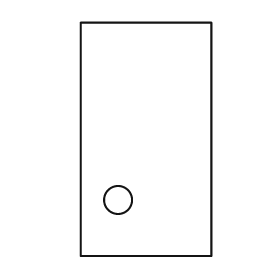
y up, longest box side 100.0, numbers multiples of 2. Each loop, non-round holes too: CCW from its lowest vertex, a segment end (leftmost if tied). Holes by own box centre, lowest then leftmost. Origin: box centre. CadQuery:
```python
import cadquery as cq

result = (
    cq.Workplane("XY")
    .moveTo(-28.0, -50.0)
    .lineTo(28.0, -50.0)
    .lineTo(28.0, 50.0)
    .lineTo(-28.0, 50.0)
    .close()
    .moveTo(-12.0, -26.0)
    .circle(6.0)
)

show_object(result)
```